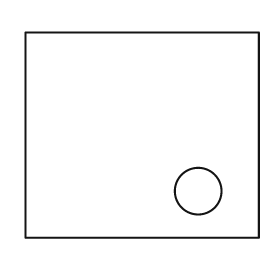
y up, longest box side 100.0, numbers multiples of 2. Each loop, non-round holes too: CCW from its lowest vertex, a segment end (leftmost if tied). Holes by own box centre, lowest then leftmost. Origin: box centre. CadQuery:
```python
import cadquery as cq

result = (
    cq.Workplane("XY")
    .moveTo(-50.0, -44.0)
    .lineTo(50.0, -44.0)
    .lineTo(50.0, 44.0)
    .lineTo(-50.0, 44.0)
    .close()
    .moveTo(24.0, -24.0)
    .circle(10.0)
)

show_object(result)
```